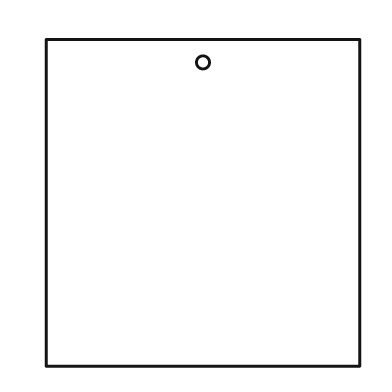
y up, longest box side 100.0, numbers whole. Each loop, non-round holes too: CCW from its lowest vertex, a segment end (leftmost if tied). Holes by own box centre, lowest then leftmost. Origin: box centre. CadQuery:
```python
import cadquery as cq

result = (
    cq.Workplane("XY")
    .moveTo(-48.0, -50.0)
    .lineTo(48.0, -50.0)
    .lineTo(48.0, 50.0)
    .lineTo(-48.0, 50.0)
    .close()
    .moveTo(0.0, 43.0)
    .circle(2.0)
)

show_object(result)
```